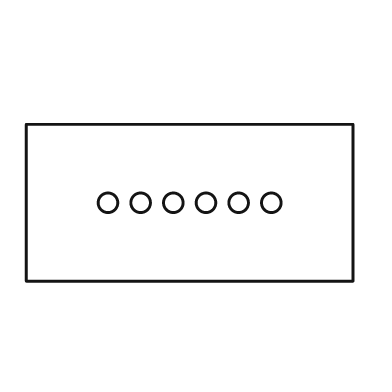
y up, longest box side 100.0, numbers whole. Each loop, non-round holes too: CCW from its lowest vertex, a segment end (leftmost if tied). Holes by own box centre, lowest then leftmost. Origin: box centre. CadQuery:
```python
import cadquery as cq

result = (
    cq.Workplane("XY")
    .moveTo(-50.0, -24.0)
    .lineTo(50.0, -24.0)
    .lineTo(50.0, 24.0)
    .lineTo(-50.0, 24.0)
    .close()
    .moveTo(-25.0, 0.0)
    .circle(3.0)
    .moveTo(-15.0, 0.0)
    .circle(3.0)
    .moveTo(-5.0, 0.0)
    .circle(3.0)
    .moveTo(5.0, 0.0)
    .circle(3.0)
    .moveTo(15.0, 0.0)
    .circle(3.0)
    .moveTo(25.0, 0.0)
    .circle(3.0)
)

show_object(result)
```